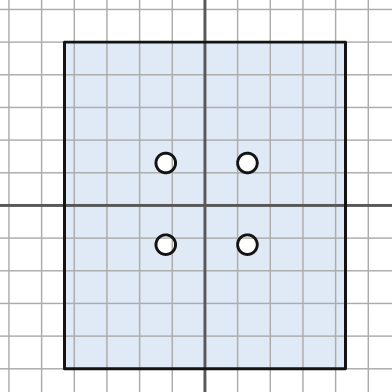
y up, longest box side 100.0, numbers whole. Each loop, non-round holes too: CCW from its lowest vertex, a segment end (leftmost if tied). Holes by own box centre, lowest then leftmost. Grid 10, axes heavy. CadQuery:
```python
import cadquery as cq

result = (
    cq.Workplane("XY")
    .moveTo(-43.0, -50.0)
    .lineTo(43.0, -50.0)
    .lineTo(43.0, 50.0)
    .lineTo(-43.0, 50.0)
    .close()
    .moveTo(-12.0, -12.0)
    .circle(3.0)
    .moveTo(13.0, -12.0)
    .circle(3.0)
    .moveTo(-12.0, 13.0)
    .circle(3.0)
    .moveTo(13.0, 13.0)
    .circle(3.0)
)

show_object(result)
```